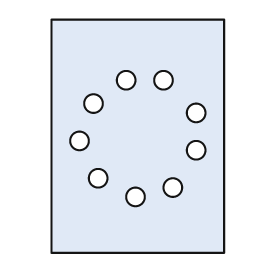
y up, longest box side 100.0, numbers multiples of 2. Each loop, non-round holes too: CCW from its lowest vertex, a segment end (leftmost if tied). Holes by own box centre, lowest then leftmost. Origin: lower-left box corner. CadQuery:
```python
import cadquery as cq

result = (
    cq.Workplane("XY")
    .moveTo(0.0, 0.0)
    .lineTo(74.0, 0.0)
    .lineTo(74.0, 100.0)
    .lineTo(0.0, 100.0)
    .close()
    .moveTo(36.0, 24.0)
    .circle(4.0)
    .moveTo(52.0, 28.0)
    .circle(4.0)
    .moveTo(20.0, 32.0)
    .circle(4.0)
    .moveTo(62.0, 44.0)
    .circle(4.0)
    .moveTo(12.0, 48.0)
    .circle(4.0)
    .moveTo(62.0, 60.0)
    .circle(4.0)
    .moveTo(18.0, 64.0)
    .circle(4.0)
    .moveTo(32.0, 74.0)
    .circle(4.0)
    .moveTo(48.0, 74.0)
    .circle(4.0)
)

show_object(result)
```